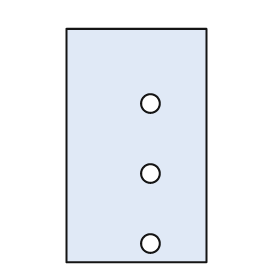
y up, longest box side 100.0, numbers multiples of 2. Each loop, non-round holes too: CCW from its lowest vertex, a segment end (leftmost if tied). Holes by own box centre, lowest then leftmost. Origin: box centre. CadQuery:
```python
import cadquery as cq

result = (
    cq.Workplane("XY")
    .moveTo(-30.0, -50.0)
    .lineTo(30.0, -50.0)
    .lineTo(30.0, 50.0)
    .lineTo(-30.0, 50.0)
    .close()
    .moveTo(6.0, -42.0)
    .circle(4.0)
    .moveTo(6.0, -12.0)
    .circle(4.0)
    .moveTo(6.0, 18.0)
    .circle(4.0)
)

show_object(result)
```